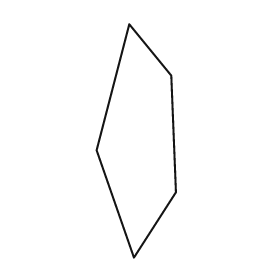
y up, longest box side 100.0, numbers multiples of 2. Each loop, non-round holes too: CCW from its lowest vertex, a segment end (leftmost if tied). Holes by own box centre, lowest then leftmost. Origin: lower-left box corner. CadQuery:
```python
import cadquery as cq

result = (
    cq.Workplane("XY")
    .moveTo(16.0, 0.0)
    .lineTo(34.0, 28.0)
    .lineTo(32.0, 78.0)
    .lineTo(14.0, 100.0)
    .lineTo(0.0, 46.0)
    .close()
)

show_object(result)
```